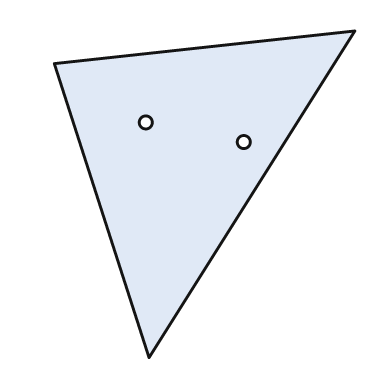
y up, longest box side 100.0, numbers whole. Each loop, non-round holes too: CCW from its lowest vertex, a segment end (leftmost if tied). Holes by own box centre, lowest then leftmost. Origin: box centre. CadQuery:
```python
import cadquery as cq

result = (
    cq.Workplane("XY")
    .moveTo(-17.0, -50.0)
    .lineTo(46.0, 50.0)
    .lineTo(-46.0, 40.0)
    .close()
    .moveTo(12.0, 16.0)
    .circle(2.0)
    .moveTo(-18.0, 22.0)
    .circle(2.0)
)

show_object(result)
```